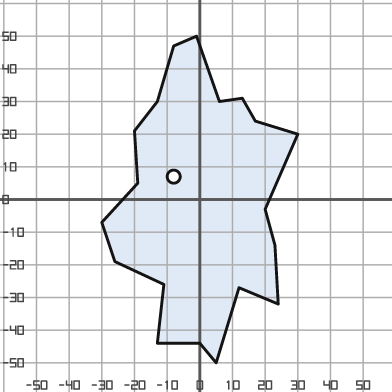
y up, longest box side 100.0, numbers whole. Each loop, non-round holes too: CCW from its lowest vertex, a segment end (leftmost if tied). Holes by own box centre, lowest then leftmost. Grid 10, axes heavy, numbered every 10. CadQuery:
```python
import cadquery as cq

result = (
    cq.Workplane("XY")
    .moveTo(5.0, -50.0)
    .lineTo(12.0, -27.0)
    .lineTo(24.0, -32.0)
    .lineTo(23.0, -14.0)
    .lineTo(20.0, -3.0)
    .lineTo(30.0, 20.0)
    .lineTo(17.0, 24.0)
    .lineTo(13.0, 31.0)
    .lineTo(6.0, 30.0)
    .lineTo(-1.0, 50.0)
    .lineTo(-8.0, 47.0)
    .lineTo(-13.0, 30.0)
    .lineTo(-20.0, 21.0)
    .lineTo(-19.0, 5.0)
    .lineTo(-30.0, -7.0)
    .lineTo(-26.0, -19.0)
    .lineTo(-11.0, -26.0)
    .lineTo(-13.0, -44.0)
    .lineTo(0.0, -44.0)
    .close()
    .moveTo(-8.0, 7.0)
    .circle(2.0)
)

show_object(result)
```